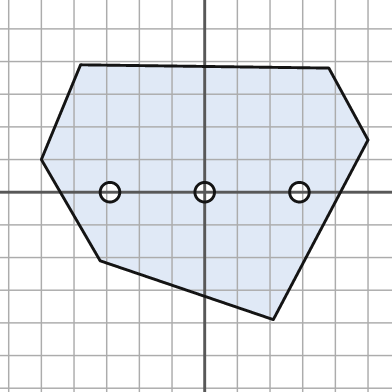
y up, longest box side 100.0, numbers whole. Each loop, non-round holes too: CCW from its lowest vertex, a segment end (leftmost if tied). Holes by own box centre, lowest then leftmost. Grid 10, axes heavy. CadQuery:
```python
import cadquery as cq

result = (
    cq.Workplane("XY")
    .moveTo(21.0, -39.0)
    .lineTo(50.0, 16.0)
    .lineTo(38.0, 38.0)
    .lineTo(-38.0, 39.0)
    .lineTo(-50.0, 10.0)
    .lineTo(-32.0, -21.0)
    .close()
    .moveTo(-29.0, 0.0)
    .circle(3.0)
    .moveTo(0.0, 0.0)
    .circle(3.0)
    .moveTo(29.0, 0.0)
    .circle(3.0)
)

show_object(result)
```